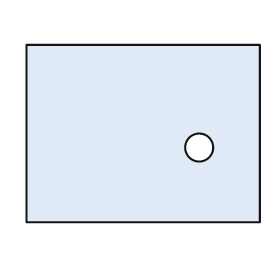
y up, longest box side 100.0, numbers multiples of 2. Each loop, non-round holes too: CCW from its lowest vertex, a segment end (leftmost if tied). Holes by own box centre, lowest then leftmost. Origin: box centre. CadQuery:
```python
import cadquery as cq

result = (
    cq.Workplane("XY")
    .moveTo(-50.0, -38.0)
    .lineTo(50.0, -38.0)
    .lineTo(50.0, 38.0)
    .lineTo(-50.0, 38.0)
    .close()
    .moveTo(24.0, -6.0)
    .circle(6.0)
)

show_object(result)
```